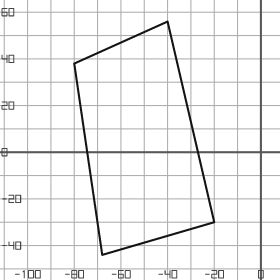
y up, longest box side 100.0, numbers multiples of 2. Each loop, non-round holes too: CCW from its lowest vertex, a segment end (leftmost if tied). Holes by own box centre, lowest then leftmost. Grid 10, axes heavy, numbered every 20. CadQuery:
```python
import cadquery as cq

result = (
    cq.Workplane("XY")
    .moveTo(-68.0, -44.0)
    .lineTo(-20.0, -30.0)
    .lineTo(-40.0, 56.0)
    .lineTo(-80.0, 38.0)
    .close()
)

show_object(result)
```